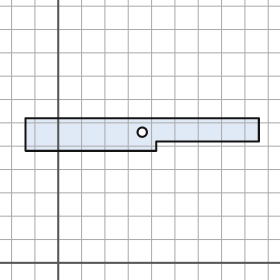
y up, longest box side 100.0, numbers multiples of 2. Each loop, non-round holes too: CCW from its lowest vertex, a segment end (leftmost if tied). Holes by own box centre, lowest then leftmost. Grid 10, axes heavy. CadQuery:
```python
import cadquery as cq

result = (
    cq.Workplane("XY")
    .moveTo(-14.0, 48.0)
    .lineTo(42.0, 48.0)
    .lineTo(42.0, 52.0)
    .lineTo(86.0, 52.0)
    .lineTo(86.0, 62.0)
    .lineTo(-14.0, 62.0)
    .close()
    .moveTo(36.0, 56.0)
    .circle(2.0)
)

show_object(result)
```